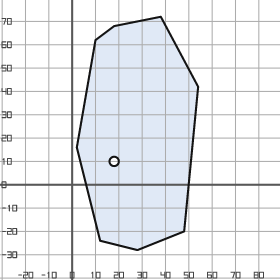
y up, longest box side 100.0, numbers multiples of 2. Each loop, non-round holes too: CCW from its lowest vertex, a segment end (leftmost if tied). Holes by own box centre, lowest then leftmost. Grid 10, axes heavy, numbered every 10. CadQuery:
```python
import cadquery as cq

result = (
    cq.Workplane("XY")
    .moveTo(28.0, -28.0)
    .lineTo(48.0, -20.0)
    .lineTo(54.0, 42.0)
    .lineTo(38.0, 72.0)
    .lineTo(18.0, 68.0)
    .lineTo(10.0, 62.0)
    .lineTo(2.0, 16.0)
    .lineTo(12.0, -24.0)
    .close()
    .moveTo(18.0, 10.0)
    .circle(2.0)
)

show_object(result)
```